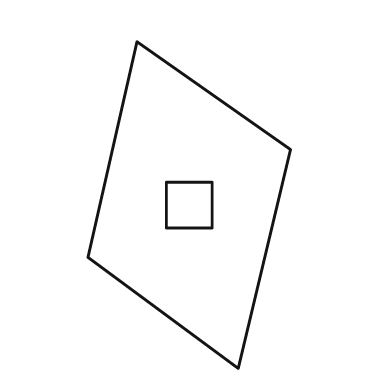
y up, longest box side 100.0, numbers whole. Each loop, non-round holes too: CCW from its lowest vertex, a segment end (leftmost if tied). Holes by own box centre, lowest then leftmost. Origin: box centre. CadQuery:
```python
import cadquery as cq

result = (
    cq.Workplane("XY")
    .moveTo(15.0, -50.0)
    .lineTo(31.0, 17.0)
    .lineTo(-16.0, 50.0)
    .lineTo(-31.0, -16.0)
    .close()
    .moveTo(-7.0, -7.0)
    .lineTo(7.0, -7.0)
    .lineTo(7.0, 7.0)
    .lineTo(-7.0, 7.0)
    .close()
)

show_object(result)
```